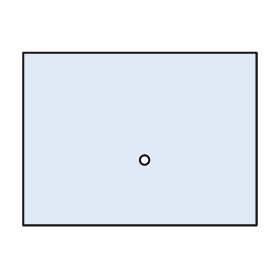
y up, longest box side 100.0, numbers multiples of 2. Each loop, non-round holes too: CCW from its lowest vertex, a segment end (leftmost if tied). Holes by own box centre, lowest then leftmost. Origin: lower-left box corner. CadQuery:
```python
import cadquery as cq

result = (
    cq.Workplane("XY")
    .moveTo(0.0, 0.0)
    .lineTo(100.0, 0.0)
    .lineTo(100.0, 74.0)
    .lineTo(0.0, 74.0)
    .close()
    .moveTo(52.0, 28.0)
    .circle(2.0)
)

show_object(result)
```